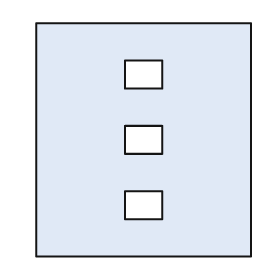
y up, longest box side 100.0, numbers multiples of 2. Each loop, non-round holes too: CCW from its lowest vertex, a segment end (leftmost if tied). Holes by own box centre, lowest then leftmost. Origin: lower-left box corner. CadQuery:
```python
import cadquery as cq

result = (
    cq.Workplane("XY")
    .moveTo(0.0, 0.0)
    .lineTo(92.0, 0.0)
    .lineTo(92.0, 100.0)
    .lineTo(0.0, 100.0)
    .close()
    .moveTo(38.0, 16.0)
    .lineTo(54.0, 16.0)
    .lineTo(54.0, 28.0)
    .lineTo(38.0, 28.0)
    .close()
    .moveTo(38.0, 44.0)
    .lineTo(54.0, 44.0)
    .lineTo(54.0, 56.0)
    .lineTo(38.0, 56.0)
    .close()
    .moveTo(38.0, 72.0)
    .lineTo(54.0, 72.0)
    .lineTo(54.0, 84.0)
    .lineTo(38.0, 84.0)
    .close()
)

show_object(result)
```